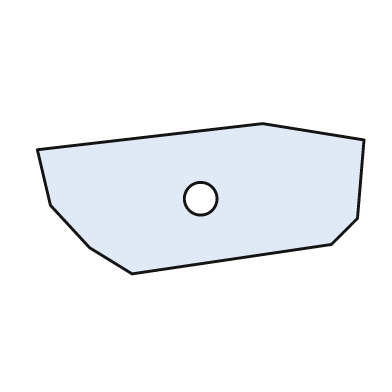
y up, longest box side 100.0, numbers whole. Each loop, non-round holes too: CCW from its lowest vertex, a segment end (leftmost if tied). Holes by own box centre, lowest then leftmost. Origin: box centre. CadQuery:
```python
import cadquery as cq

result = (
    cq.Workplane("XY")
    .moveTo(-21.0, -23.0)
    .lineTo(40.0, -14.0)
    .lineTo(48.0, -6.0)
    .lineTo(50.0, 18.0)
    .lineTo(19.0, 23.0)
    .lineTo(-50.0, 15.0)
    .lineTo(-46.0, -2.0)
    .lineTo(-34.0, -15.0)
    .close()
    .moveTo(0.0, 0.0)
    .circle(5.0)
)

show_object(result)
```